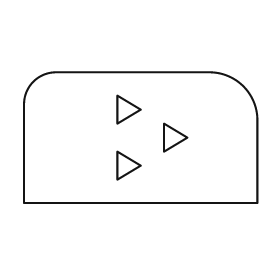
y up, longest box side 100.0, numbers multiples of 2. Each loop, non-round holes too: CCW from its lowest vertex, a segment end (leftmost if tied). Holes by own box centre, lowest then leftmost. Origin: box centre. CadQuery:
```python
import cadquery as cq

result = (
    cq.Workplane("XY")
    .moveTo(-50.0, -28.0)
    .lineTo(50.0, -28.0)
    .lineTo(50.0, 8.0)
    .threePointArc((44.0, 22.0), (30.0, 28.0))
    .lineTo(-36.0, 28.0)
    .threePointArc((-46.0, 24.0), (-50.0, 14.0))
    .close()
    .moveTo(-10.0, -18.0)
    .lineTo(0.0, -12.0)
    .lineTo(-10.0, -6.0)
    .close()
    .moveTo(10.0, -6.0)
    .lineTo(20.0, 0.0)
    .lineTo(10.0, 6.0)
    .close()
    .moveTo(-10.0, 6.0)
    .lineTo(0.0, 12.0)
    .lineTo(-10.0, 18.0)
    .close()
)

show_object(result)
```